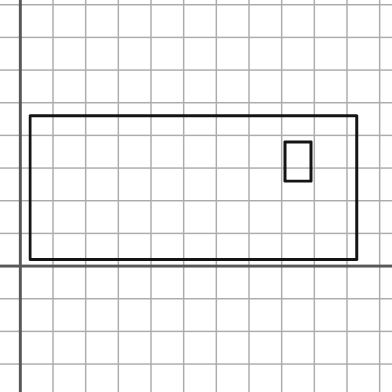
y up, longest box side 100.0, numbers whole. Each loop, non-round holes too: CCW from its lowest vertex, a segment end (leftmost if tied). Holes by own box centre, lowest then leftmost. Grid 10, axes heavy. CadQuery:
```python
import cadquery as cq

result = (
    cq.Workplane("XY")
    .moveTo(3.0, 2.0)
    .lineTo(103.0, 2.0)
    .lineTo(103.0, 46.0)
    .lineTo(3.0, 46.0)
    .close()
    .moveTo(81.0, 26.0)
    .lineTo(89.0, 26.0)
    .lineTo(89.0, 38.0)
    .lineTo(81.0, 38.0)
    .close()
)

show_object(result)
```